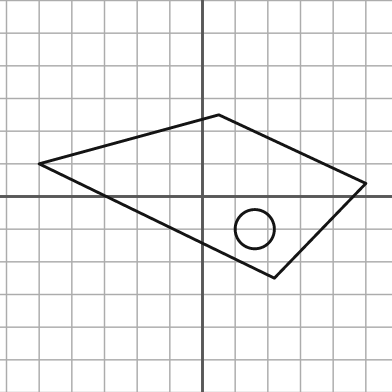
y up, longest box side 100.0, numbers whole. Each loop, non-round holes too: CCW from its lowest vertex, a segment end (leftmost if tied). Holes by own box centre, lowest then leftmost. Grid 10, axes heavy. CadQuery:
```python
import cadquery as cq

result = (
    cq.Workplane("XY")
    .moveTo(22.0, -25.0)
    .lineTo(50.0, 4.0)
    .lineTo(5.0, 25.0)
    .lineTo(-50.0, 10.0)
    .close()
    .moveTo(16.0, -10.0)
    .circle(6.0)
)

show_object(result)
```